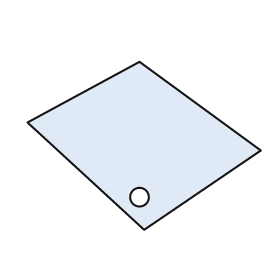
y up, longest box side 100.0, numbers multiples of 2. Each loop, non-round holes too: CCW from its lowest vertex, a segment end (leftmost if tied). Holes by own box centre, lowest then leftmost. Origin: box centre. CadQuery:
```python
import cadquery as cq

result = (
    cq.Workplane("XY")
    .moveTo(0.0, -36.0)
    .lineTo(50.0, -2.0)
    .lineTo(-2.0, 36.0)
    .lineTo(-50.0, 10.0)
    .close()
    .moveTo(-2.0, -22.0)
    .circle(4.0)
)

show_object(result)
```